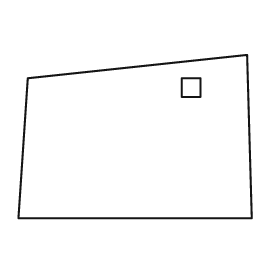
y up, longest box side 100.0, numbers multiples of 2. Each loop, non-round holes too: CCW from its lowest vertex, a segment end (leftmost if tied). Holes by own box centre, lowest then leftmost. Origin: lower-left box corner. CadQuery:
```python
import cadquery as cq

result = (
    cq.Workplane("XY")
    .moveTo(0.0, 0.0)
    .lineTo(100.0, 0.0)
    .lineTo(98.0, 70.0)
    .lineTo(4.0, 60.0)
    .close()
    .moveTo(70.0, 52.0)
    .lineTo(78.0, 52.0)
    .lineTo(78.0, 60.0)
    .lineTo(70.0, 60.0)
    .close()
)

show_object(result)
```